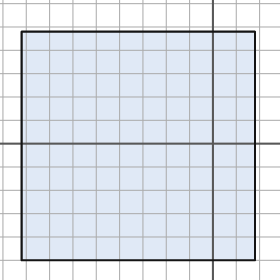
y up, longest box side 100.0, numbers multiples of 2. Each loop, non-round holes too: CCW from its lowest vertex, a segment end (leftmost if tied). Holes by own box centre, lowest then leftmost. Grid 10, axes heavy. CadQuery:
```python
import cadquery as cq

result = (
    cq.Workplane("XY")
    .moveTo(-82.0, -50.0)
    .lineTo(18.0, -50.0)
    .lineTo(18.0, 48.0)
    .lineTo(-82.0, 48.0)
    .close()
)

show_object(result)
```